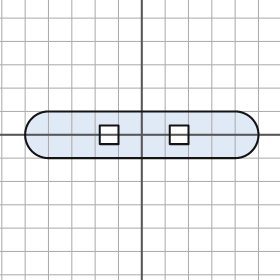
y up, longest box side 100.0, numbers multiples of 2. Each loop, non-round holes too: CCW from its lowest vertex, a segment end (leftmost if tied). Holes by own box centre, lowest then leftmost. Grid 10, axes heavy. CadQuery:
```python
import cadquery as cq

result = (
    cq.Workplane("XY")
    .moveTo(-40.0, -10.0)
    .lineTo(40.0, -10.0)
    .threePointArc((50.0, 0.0), (40.0, 10.0))
    .lineTo(-40.0, 10.0)
    .threePointArc((-50.0, 0.0), (-40.0, -10.0))
    .close()
    .moveTo(-18.0, -4.0)
    .lineTo(-10.0, -4.0)
    .lineTo(-10.0, 4.0)
    .lineTo(-18.0, 4.0)
    .close()
    .moveTo(12.0, -4.0)
    .lineTo(20.0, -4.0)
    .lineTo(20.0, 4.0)
    .lineTo(12.0, 4.0)
    .close()
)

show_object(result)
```